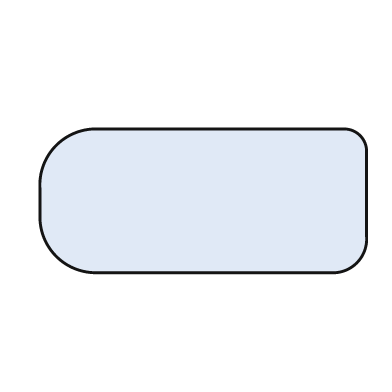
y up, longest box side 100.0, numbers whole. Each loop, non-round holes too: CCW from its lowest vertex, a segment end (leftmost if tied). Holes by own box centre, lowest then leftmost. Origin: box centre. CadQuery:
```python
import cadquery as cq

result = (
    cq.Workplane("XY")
    .moveTo(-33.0, -22.0)
    .lineTo(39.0, -22.0)
    .threePointArc((47.0, -19.0), (50.0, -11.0))
    .lineTo(50.0, 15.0)
    .threePointArc((48.0, 20.0), (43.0, 22.0))
    .lineTo(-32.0, 22.0)
    .threePointArc((-45.0, 17.0), (-50.0, 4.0))
    .lineTo(-50.0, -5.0)
    .threePointArc((-45.0, -17.0), (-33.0, -22.0))
    .close()
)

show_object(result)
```